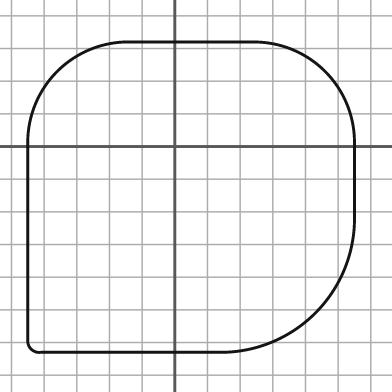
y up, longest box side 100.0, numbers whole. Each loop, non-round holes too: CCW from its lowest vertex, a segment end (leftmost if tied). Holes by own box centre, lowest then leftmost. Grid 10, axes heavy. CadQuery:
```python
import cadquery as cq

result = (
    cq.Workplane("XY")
    .moveTo(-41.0, -63.0)
    .lineTo(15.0, -63.0)
    .threePointArc((43.0, -51.0), (55.0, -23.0))
    .lineTo(55.0, 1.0)
    .threePointArc((46.0, 23.0), (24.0, 32.0))
    .lineTo(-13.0, 32.0)
    .threePointArc((-36.0, 23.0), (-45.0, 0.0))
    .lineTo(-45.0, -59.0)
    .threePointArc((-44.0, -62.0), (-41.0, -63.0))
    .close()
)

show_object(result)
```